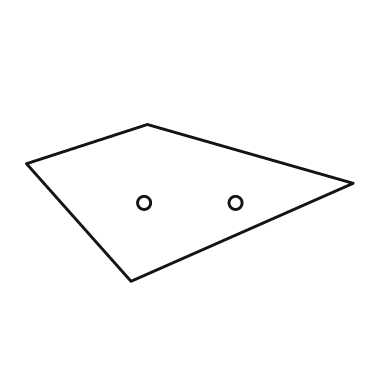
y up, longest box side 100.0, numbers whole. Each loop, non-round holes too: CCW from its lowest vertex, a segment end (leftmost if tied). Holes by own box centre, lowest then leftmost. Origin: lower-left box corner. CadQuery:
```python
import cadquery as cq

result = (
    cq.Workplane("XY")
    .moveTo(32.0, 0.0)
    .lineTo(100.0, 30.0)
    .lineTo(37.0, 48.0)
    .lineTo(0.0, 36.0)
    .close()
    .moveTo(36.0, 24.0)
    .circle(2.0)
    .moveTo(64.0, 24.0)
    .circle(2.0)
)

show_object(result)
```